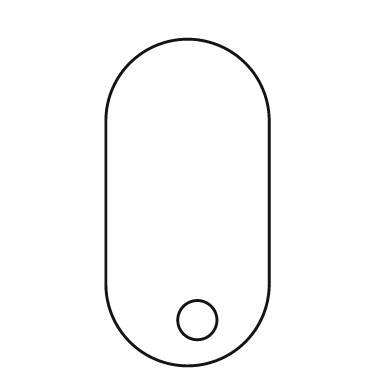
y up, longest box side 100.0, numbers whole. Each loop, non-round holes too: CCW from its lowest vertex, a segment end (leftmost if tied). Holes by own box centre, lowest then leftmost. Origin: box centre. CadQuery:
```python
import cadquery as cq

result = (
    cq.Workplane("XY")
    .moveTo(-25.0, -25.0)
    .threePointArc((0.0, -50.0), (25.0, -25.0))
    .lineTo(25.0, 25.0)
    .threePointArc((0.0, 50.0), (-25.0, 25.0))
    .close()
    .moveTo(3.0, -36.0)
    .circle(6.0)
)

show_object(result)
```